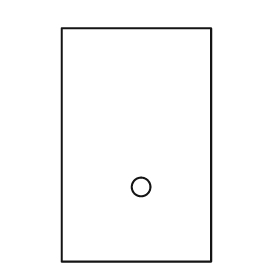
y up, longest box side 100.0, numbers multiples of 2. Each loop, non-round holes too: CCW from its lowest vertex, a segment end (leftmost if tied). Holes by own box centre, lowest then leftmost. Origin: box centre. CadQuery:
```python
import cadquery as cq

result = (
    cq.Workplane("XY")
    .moveTo(-32.0, -50.0)
    .lineTo(32.0, -50.0)
    .lineTo(32.0, 50.0)
    .lineTo(-32.0, 50.0)
    .close()
    .moveTo(2.0, -18.0)
    .circle(4.0)
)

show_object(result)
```